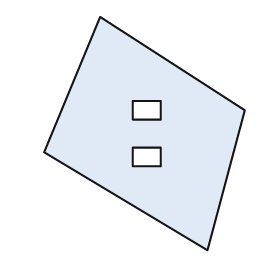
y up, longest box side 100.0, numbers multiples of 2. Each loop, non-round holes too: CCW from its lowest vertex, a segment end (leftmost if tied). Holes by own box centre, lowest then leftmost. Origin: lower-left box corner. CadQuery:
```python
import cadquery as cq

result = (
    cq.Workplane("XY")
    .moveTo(70.0, 0.0)
    .lineTo(86.0, 60.0)
    .lineTo(24.0, 100.0)
    .lineTo(0.0, 42.0)
    .close()
    .moveTo(38.0, 36.0)
    .lineTo(50.0, 36.0)
    .lineTo(50.0, 44.0)
    .lineTo(38.0, 44.0)
    .close()
    .moveTo(38.0, 56.0)
    .lineTo(50.0, 56.0)
    .lineTo(50.0, 64.0)
    .lineTo(38.0, 64.0)
    .close()
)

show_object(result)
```